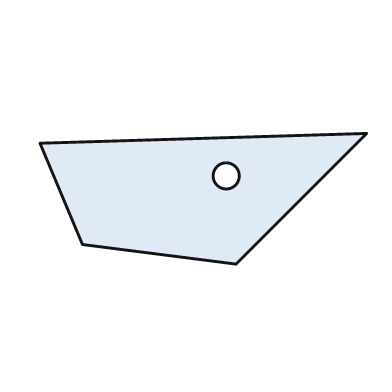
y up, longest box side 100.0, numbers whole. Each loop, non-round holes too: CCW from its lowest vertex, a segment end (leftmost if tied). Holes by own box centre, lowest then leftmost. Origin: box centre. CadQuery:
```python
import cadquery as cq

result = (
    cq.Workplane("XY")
    .moveTo(10.0, -20.0)
    .lineTo(50.0, 20.0)
    .lineTo(-50.0, 17.0)
    .lineTo(-37.0, -14.0)
    .close()
    .moveTo(7.0, 7.0)
    .circle(4.0)
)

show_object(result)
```